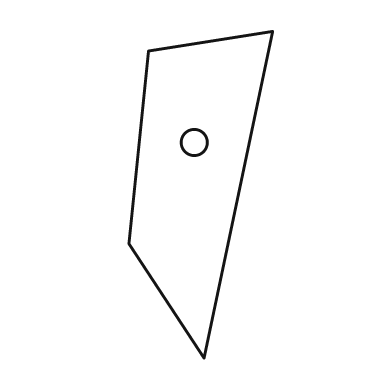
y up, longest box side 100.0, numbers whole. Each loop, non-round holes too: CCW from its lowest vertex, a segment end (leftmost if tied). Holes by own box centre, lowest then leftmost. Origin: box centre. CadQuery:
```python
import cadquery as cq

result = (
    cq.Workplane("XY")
    .moveTo(1.0, -50.0)
    .lineTo(22.0, 50.0)
    .lineTo(-16.0, 44.0)
    .lineTo(-22.0, -15.0)
    .close()
    .moveTo(-2.0, 16.0)
    .circle(4.0)
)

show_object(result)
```